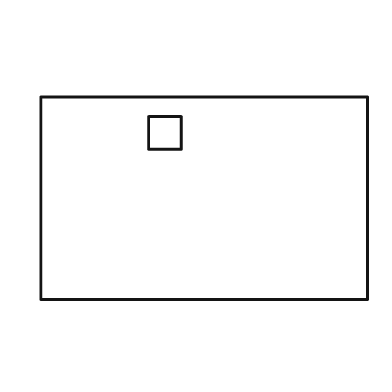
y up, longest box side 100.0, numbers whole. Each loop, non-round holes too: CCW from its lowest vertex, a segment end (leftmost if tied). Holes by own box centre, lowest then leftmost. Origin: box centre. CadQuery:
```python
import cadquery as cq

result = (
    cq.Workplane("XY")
    .moveTo(-50.0, -31.0)
    .lineTo(50.0, -31.0)
    .lineTo(50.0, 31.0)
    .lineTo(-50.0, 31.0)
    .close()
    .moveTo(-17.0, 15.0)
    .lineTo(-7.0, 15.0)
    .lineTo(-7.0, 25.0)
    .lineTo(-17.0, 25.0)
    .close()
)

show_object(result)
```